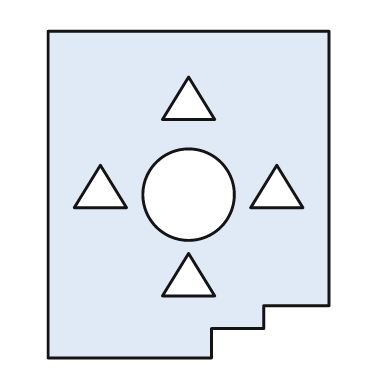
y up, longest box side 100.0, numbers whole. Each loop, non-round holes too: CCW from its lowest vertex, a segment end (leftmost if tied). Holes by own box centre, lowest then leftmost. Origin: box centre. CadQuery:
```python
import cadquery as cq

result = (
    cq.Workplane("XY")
    .moveTo(-43.0, -50.0)
    .lineTo(7.0, -50.0)
    .lineTo(7.0, -41.0)
    .lineTo(23.0, -41.0)
    .lineTo(23.0, -34.0)
    .lineTo(43.0, -34.0)
    .lineTo(43.0, 50.0)
    .lineTo(-43.0, 50.0)
    .close()
    .moveTo(-8.0, -31.0)
    .lineTo(8.0, -31.0)
    .lineTo(0.0, -18.0)
    .close()
    .moveTo(0.0, 0.0)
    .circle(14.0)
    .moveTo(-35.0, -4.0)
    .lineTo(-19.0, -4.0)
    .lineTo(-27.0, 9.0)
    .close()
    .moveTo(19.0, -4.0)
    .lineTo(35.0, -4.0)
    .lineTo(27.0, 9.0)
    .close()
    .moveTo(-8.0, 23.0)
    .lineTo(8.0, 23.0)
    .lineTo(0.0, 36.0)
    .close()
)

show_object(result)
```